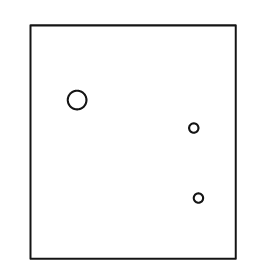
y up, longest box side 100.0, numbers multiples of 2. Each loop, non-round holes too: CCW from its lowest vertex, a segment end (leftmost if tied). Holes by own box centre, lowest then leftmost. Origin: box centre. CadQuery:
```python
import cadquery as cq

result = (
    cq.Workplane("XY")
    .moveTo(-44.0, -50.0)
    .lineTo(44.0, -50.0)
    .lineTo(44.0, 50.0)
    .lineTo(-44.0, 50.0)
    .close()
    .moveTo(28.0, -24.0)
    .circle(2.0)
    .moveTo(26.0, 6.0)
    .circle(2.0)
    .moveTo(-24.0, 18.0)
    .circle(4.0)
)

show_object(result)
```